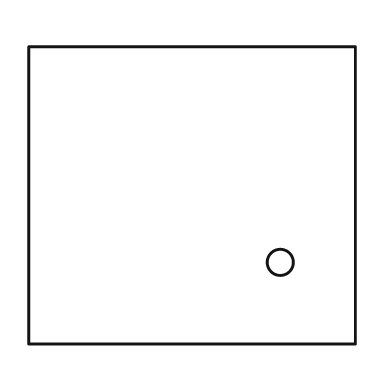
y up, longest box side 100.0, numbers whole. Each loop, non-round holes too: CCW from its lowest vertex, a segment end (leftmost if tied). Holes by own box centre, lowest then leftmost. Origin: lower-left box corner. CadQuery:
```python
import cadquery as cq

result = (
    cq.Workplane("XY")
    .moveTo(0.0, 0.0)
    .lineTo(100.0, 0.0)
    .lineTo(100.0, 91.0)
    .lineTo(0.0, 91.0)
    .close()
    .moveTo(77.0, 25.0)
    .circle(4.0)
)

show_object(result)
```